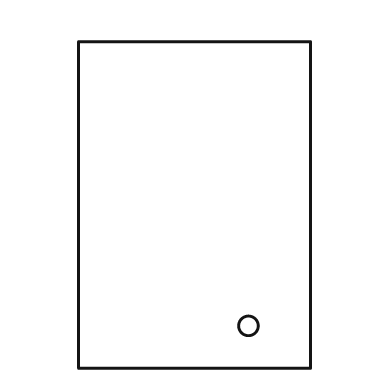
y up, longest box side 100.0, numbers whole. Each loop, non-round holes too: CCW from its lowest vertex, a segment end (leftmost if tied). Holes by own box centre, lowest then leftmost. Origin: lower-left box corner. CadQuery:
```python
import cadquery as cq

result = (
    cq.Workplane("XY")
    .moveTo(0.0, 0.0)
    .lineTo(71.0, 0.0)
    .lineTo(71.0, 100.0)
    .lineTo(0.0, 100.0)
    .close()
    .moveTo(52.0, 13.0)
    .circle(3.0)
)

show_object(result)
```